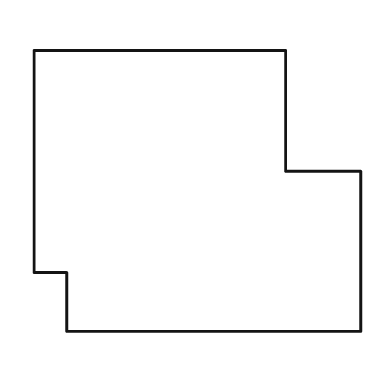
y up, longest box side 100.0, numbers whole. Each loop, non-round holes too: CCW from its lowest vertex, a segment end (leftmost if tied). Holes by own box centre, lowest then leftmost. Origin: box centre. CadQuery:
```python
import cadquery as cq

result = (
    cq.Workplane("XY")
    .moveTo(-40.0, -43.0)
    .lineTo(50.0, -43.0)
    .lineTo(50.0, 6.0)
    .lineTo(27.0, 6.0)
    .lineTo(27.0, 43.0)
    .lineTo(-50.0, 43.0)
    .lineTo(-50.0, -25.0)
    .lineTo(-40.0, -25.0)
    .close()
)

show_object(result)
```